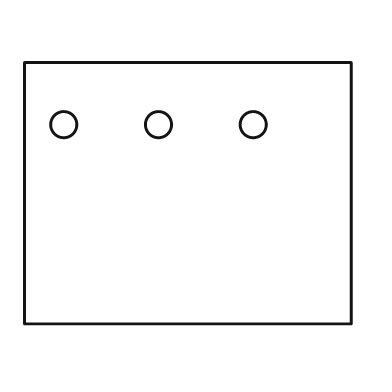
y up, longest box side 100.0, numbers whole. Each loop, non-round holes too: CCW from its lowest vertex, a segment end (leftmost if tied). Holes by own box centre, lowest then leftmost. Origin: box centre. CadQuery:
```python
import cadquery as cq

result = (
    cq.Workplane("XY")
    .moveTo(-50.0, -40.0)
    .lineTo(50.0, -40.0)
    .lineTo(50.0, 40.0)
    .lineTo(-50.0, 40.0)
    .close()
    .moveTo(-38.0, 21.0)
    .circle(4.0)
    .moveTo(-9.0, 21.0)
    .circle(4.0)
    .moveTo(20.0, 21.0)
    .circle(4.0)
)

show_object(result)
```